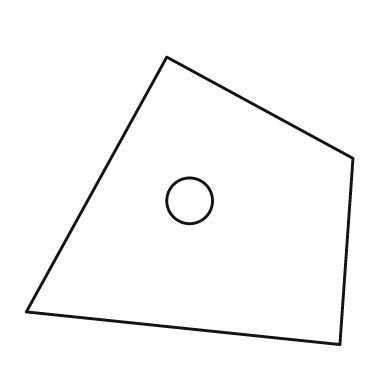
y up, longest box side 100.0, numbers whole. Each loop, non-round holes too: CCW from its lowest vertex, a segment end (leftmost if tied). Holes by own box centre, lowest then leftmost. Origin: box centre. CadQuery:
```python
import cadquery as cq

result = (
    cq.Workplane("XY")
    .moveTo(46.0, -44.0)
    .lineTo(50.0, 13.0)
    .lineTo(-7.0, 44.0)
    .lineTo(-50.0, -34.0)
    .close()
    .moveTo(0.0, 0.0)
    .circle(7.0)
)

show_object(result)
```